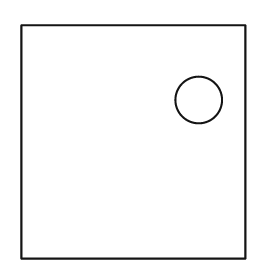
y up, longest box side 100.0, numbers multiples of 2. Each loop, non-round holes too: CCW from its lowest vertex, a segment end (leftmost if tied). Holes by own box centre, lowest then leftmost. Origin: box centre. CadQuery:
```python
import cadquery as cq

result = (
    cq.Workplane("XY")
    .moveTo(-48.0, -50.0)
    .lineTo(48.0, -50.0)
    .lineTo(48.0, 50.0)
    .lineTo(-48.0, 50.0)
    .close()
    .moveTo(28.0, 18.0)
    .circle(10.0)
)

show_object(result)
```